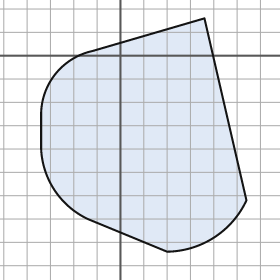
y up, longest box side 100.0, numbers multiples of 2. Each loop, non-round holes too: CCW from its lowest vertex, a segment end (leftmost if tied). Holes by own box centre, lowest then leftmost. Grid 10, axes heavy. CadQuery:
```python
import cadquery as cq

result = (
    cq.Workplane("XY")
    .moveTo(20.0, -84.0)
    .threePointArc((40.0, -78.0), (54.0, -62.0))
    .lineTo(36.0, 16.0)
    .lineTo(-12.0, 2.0)
    .threePointArc((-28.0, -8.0), (-34.0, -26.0))
    .lineTo(-34.0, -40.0)
    .threePointArc((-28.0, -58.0), (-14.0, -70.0))
    .close()
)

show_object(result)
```